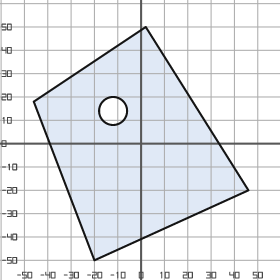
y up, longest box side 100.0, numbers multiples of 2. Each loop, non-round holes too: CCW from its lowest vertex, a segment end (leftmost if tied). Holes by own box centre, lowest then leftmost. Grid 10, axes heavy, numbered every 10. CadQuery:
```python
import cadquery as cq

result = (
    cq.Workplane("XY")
    .moveTo(-20.0, -50.0)
    .lineTo(46.0, -20.0)
    .lineTo(2.0, 50.0)
    .lineTo(-46.0, 18.0)
    .close()
    .moveTo(-12.0, 14.0)
    .circle(6.0)
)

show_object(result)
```